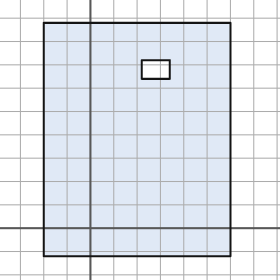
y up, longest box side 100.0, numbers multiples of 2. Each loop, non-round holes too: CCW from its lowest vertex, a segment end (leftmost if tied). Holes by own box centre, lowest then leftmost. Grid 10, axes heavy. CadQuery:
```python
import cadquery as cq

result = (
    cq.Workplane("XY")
    .moveTo(-20.0, -12.0)
    .lineTo(60.0, -12.0)
    .lineTo(60.0, 88.0)
    .lineTo(-20.0, 88.0)
    .close()
    .moveTo(22.0, 64.0)
    .lineTo(34.0, 64.0)
    .lineTo(34.0, 72.0)
    .lineTo(22.0, 72.0)
    .close()
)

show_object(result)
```